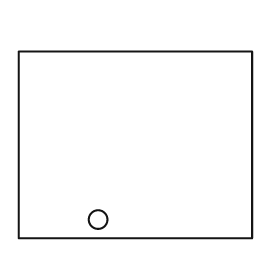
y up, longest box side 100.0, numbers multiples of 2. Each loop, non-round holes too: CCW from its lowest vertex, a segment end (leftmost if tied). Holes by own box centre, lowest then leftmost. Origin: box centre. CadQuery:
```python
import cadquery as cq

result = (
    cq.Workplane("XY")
    .moveTo(-50.0, -40.0)
    .lineTo(50.0, -40.0)
    .lineTo(50.0, 40.0)
    .lineTo(-50.0, 40.0)
    .close()
    .moveTo(-16.0, -32.0)
    .circle(4.0)
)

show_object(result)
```